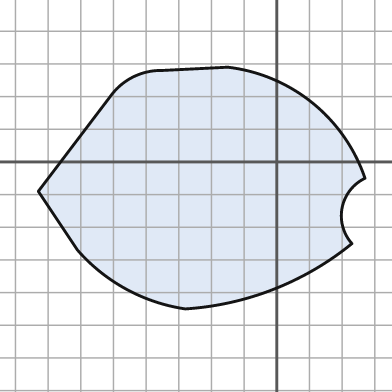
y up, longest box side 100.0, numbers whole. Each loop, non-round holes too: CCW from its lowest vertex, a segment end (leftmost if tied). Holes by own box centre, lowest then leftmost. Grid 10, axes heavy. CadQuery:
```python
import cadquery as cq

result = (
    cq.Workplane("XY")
    .moveTo(-28.0, -45.0)
    .threePointArc((-1.0, -39.0), (23.0, -25.0))
    .threePointArc((20.0, -14.0), (27.0, -5.0))
    .threePointArc((11.0, 18.0), (-15.0, 29.0))
    .lineTo(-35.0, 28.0)
    .threePointArc((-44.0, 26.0), (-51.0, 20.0))
    .lineTo(-73.0, -9.0)
    .lineTo(-61.0, -27.0)
    .threePointArc((-46.0, -39.0), (-28.0, -45.0))
    .close()
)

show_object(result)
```